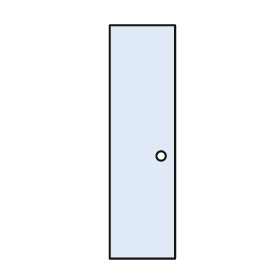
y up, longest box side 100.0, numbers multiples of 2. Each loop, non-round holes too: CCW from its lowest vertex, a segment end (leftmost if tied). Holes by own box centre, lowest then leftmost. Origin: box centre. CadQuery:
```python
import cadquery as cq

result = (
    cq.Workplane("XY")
    .moveTo(-14.0, -50.0)
    .lineTo(14.0, -50.0)
    .lineTo(14.0, 50.0)
    .lineTo(-14.0, 50.0)
    .close()
    .moveTo(8.0, -6.0)
    .circle(2.0)
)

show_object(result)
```